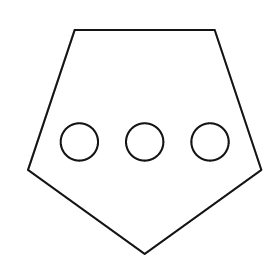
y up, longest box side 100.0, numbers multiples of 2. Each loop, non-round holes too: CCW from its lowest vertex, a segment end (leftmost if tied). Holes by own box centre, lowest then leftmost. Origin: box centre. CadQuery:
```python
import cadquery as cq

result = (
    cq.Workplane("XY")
    .moveTo(0.0, -48.0)
    .lineTo(50.0, -12.0)
    .lineTo(30.0, 48.0)
    .lineTo(-30.0, 48.0)
    .lineTo(-50.0, -12.0)
    .close()
    .moveTo(-28.0, 0.0)
    .circle(8.0)
    .moveTo(0.0, 0.0)
    .circle(8.0)
    .moveTo(28.0, 0.0)
    .circle(8.0)
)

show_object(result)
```